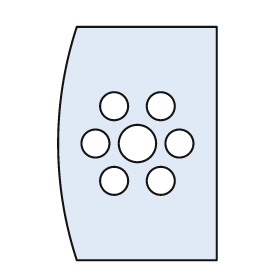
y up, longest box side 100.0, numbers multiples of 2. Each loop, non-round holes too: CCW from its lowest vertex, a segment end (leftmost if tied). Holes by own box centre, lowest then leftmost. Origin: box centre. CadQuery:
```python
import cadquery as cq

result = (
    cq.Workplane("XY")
    .moveTo(-26.0, -50.0)
    .lineTo(34.0, -50.0)
    .lineTo(34.0, 50.0)
    .lineTo(-26.0, 50.0)
    .threePointArc((-34.0, 0.0), (-26.0, -50.0))
    .close()
    .moveTo(-10.0, -16.0)
    .circle(6.0)
    .moveTo(10.0, -16.0)
    .circle(6.0)
    .moveTo(-18.0, 0.0)
    .circle(6.0)
    .moveTo(0.0, 0.0)
    .circle(8.0)
    .moveTo(18.0, 0.0)
    .circle(6.0)
    .moveTo(-10.0, 16.0)
    .circle(6.0)
    .moveTo(10.0, 16.0)
    .circle(6.0)
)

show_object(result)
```